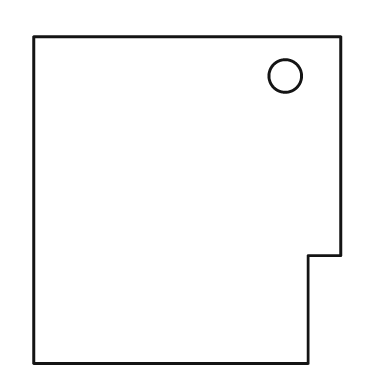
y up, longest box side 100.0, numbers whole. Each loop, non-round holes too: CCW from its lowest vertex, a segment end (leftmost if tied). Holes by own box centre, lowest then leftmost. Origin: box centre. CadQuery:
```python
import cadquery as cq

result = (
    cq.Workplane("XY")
    .moveTo(-47.0, -50.0)
    .lineTo(37.0, -50.0)
    .lineTo(37.0, -17.0)
    .lineTo(47.0, -17.0)
    .lineTo(47.0, 50.0)
    .lineTo(-47.0, 50.0)
    .close()
    .moveTo(30.0, 38.0)
    .circle(5.0)
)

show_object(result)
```